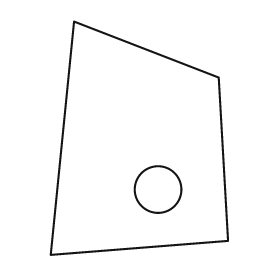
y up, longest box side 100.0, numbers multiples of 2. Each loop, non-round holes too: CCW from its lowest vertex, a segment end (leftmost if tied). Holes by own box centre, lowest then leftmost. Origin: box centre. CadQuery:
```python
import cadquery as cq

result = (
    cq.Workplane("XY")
    .moveTo(-38.0, -50.0)
    .lineTo(38.0, -44.0)
    .lineTo(34.0, 26.0)
    .lineTo(-28.0, 50.0)
    .close()
    .moveTo(8.0, -22.0)
    .circle(10.0)
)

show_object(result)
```